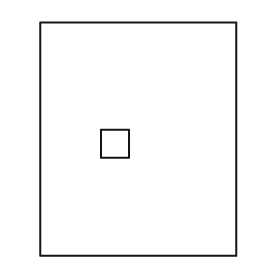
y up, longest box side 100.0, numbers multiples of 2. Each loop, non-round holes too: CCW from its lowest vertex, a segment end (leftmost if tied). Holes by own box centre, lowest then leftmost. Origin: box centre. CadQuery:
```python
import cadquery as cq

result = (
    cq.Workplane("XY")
    .moveTo(-42.0, -50.0)
    .lineTo(42.0, -50.0)
    .lineTo(42.0, 50.0)
    .lineTo(-42.0, 50.0)
    .close()
    .moveTo(-16.0, -8.0)
    .lineTo(-4.0, -8.0)
    .lineTo(-4.0, 4.0)
    .lineTo(-16.0, 4.0)
    .close()
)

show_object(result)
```